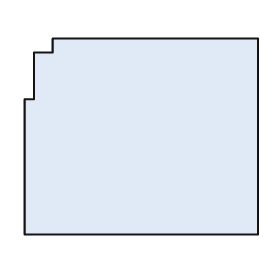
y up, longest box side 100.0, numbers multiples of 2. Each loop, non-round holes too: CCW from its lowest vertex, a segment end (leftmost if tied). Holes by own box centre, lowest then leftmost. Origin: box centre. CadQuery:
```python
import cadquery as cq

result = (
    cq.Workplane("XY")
    .moveTo(-50.0, -42.0)
    .lineTo(50.0, -42.0)
    .lineTo(50.0, 42.0)
    .lineTo(-38.0, 42.0)
    .lineTo(-38.0, 36.0)
    .lineTo(-46.0, 36.0)
    .lineTo(-46.0, 16.0)
    .lineTo(-50.0, 16.0)
    .close()
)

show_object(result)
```